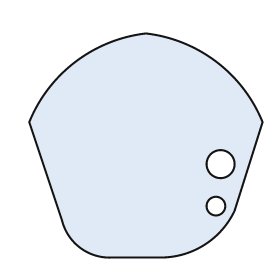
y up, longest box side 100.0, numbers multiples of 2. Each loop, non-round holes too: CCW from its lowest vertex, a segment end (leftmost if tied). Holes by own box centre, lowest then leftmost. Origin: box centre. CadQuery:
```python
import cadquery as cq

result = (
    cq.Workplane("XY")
    .moveTo(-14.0, -48.0)
    .lineTo(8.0, -48.0)
    .threePointArc((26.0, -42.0), (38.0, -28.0))
    .lineTo(50.0, 10.0)
    .threePointArc((30.0, 36.0), (0.0, 48.0))
    .threePointArc((-30.0, 36.0), (-50.0, 10.0))
    .lineTo(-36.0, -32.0)
    .threePointArc((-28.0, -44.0), (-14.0, -48.0))
    .close()
    .moveTo(30.0, -26.0)
    .circle(4.0)
    .moveTo(32.0, -8.0)
    .circle(6.0)
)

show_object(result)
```